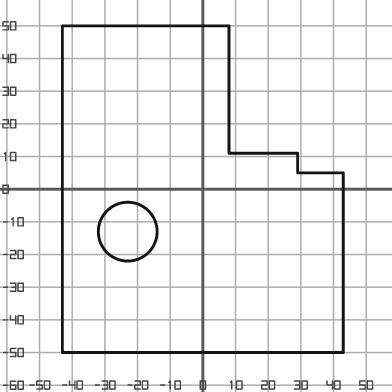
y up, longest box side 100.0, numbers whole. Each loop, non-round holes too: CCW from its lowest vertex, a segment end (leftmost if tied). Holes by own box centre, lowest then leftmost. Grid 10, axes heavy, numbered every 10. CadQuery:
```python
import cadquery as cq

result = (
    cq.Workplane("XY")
    .moveTo(-43.0, -50.0)
    .lineTo(43.0, -50.0)
    .lineTo(43.0, 5.0)
    .lineTo(29.0, 5.0)
    .lineTo(29.0, 11.0)
    .lineTo(8.0, 11.0)
    .lineTo(8.0, 50.0)
    .lineTo(-43.0, 50.0)
    .close()
    .moveTo(-23.0, -13.0)
    .circle(9.0)
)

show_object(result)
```